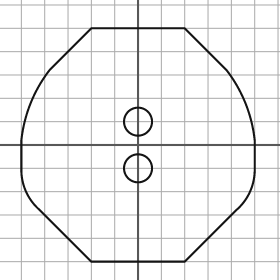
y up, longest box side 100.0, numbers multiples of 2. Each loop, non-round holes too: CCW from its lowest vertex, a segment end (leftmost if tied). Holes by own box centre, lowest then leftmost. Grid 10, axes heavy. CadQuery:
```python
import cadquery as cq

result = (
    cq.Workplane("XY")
    .moveTo(-20.0, -50.0)
    .lineTo(20.0, -50.0)
    .lineTo(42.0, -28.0)
    .threePointArc((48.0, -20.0), (50.0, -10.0))
    .lineTo(50.0, 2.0)
    .threePointArc((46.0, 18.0), (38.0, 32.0))
    .lineTo(20.0, 50.0)
    .lineTo(-20.0, 50.0)
    .lineTo(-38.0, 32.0)
    .threePointArc((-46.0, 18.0), (-50.0, 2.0))
    .lineTo(-50.0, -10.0)
    .threePointArc((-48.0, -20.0), (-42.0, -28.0))
    .close()
    .moveTo(0.0, -10.0)
    .circle(6.0)
    .moveTo(0.0, 10.0)
    .circle(6.0)
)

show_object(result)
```